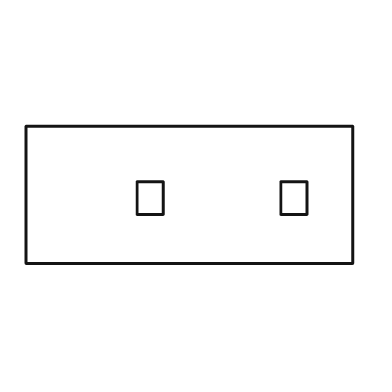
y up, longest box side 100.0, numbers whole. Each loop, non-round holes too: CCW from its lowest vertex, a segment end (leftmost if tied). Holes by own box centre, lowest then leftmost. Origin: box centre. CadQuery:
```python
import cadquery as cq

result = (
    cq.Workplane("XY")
    .moveTo(-50.0, -21.0)
    .lineTo(50.0, -21.0)
    .lineTo(50.0, 21.0)
    .lineTo(-50.0, 21.0)
    .close()
    .moveTo(-16.0, -6.0)
    .lineTo(-8.0, -6.0)
    .lineTo(-8.0, 4.0)
    .lineTo(-16.0, 4.0)
    .close()
    .moveTo(28.0, -6.0)
    .lineTo(36.0, -6.0)
    .lineTo(36.0, 4.0)
    .lineTo(28.0, 4.0)
    .close()
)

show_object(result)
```